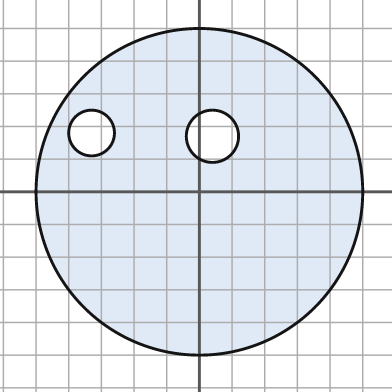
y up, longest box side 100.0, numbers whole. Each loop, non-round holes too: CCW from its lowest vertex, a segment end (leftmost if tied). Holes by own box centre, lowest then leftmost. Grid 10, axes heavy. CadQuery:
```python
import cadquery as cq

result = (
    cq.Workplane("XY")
    .moveTo(0.0, 0.0)
    .circle(50.0)
    .moveTo(4.0, 17.0)
    .circle(8.0)
    .moveTo(-33.0, 18.0)
    .circle(7.0)
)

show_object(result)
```